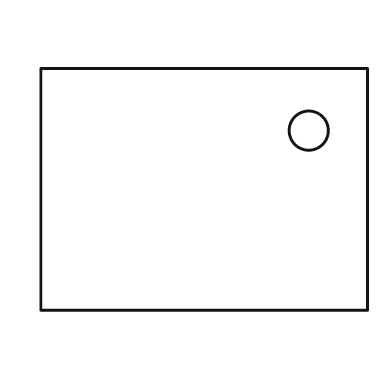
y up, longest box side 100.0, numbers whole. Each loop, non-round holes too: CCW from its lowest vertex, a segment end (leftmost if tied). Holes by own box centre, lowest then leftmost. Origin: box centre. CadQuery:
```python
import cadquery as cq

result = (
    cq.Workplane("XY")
    .moveTo(-50.0, -37.0)
    .lineTo(50.0, -37.0)
    .lineTo(50.0, 37.0)
    .lineTo(-50.0, 37.0)
    .close()
    .moveTo(32.0, 18.0)
    .circle(6.0)
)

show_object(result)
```